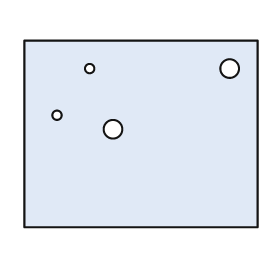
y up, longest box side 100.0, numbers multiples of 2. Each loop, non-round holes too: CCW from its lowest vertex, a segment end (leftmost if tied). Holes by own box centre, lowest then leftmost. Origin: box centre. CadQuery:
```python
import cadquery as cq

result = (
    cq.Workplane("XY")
    .moveTo(-50.0, -40.0)
    .lineTo(50.0, -40.0)
    .lineTo(50.0, 40.0)
    .lineTo(-50.0, 40.0)
    .close()
    .moveTo(-12.0, 2.0)
    .circle(4.0)
    .moveTo(-36.0, 8.0)
    .circle(2.0)
    .moveTo(-22.0, 28.0)
    .circle(2.0)
    .moveTo(38.0, 28.0)
    .circle(4.0)
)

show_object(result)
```